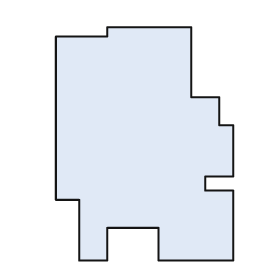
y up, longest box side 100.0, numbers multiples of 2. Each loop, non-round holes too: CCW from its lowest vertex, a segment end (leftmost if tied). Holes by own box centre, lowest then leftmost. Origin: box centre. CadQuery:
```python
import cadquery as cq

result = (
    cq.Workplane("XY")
    .moveTo(-28.0, -50.0)
    .lineTo(-16.0, -50.0)
    .lineTo(-16.0, -36.0)
    .lineTo(6.0, -36.0)
    .lineTo(6.0, -50.0)
    .lineTo(38.0, -50.0)
    .lineTo(38.0, -20.0)
    .lineTo(26.0, -20.0)
    .lineTo(26.0, -14.0)
    .lineTo(38.0, -14.0)
    .lineTo(38.0, 8.0)
    .lineTo(32.0, 8.0)
    .lineTo(32.0, 20.0)
    .lineTo(20.0, 20.0)
    .lineTo(20.0, 50.0)
    .lineTo(-16.0, 50.0)
    .lineTo(-16.0, 46.0)
    .lineTo(-38.0, 46.0)
    .lineTo(-38.0, -24.0)
    .lineTo(-28.0, -24.0)
    .close()
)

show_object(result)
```